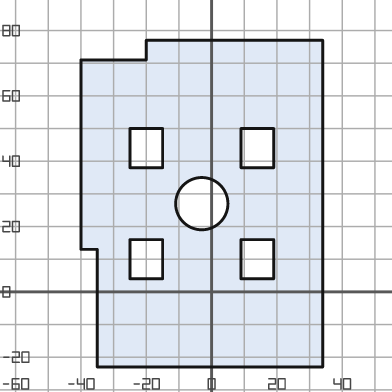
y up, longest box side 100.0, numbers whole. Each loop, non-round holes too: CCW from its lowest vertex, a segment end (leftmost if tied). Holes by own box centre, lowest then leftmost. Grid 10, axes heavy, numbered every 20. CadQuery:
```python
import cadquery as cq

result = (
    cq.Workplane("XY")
    .moveTo(-35.0, -23.0)
    .lineTo(34.0, -23.0)
    .lineTo(34.0, 77.0)
    .lineTo(-20.0, 77.0)
    .lineTo(-20.0, 71.0)
    .lineTo(-40.0, 71.0)
    .lineTo(-40.0, 13.0)
    .lineTo(-35.0, 13.0)
    .close()
    .moveTo(-25.0, 4.0)
    .lineTo(-15.0, 4.0)
    .lineTo(-15.0, 16.0)
    .lineTo(-25.0, 16.0)
    .close()
    .moveTo(9.0, 4.0)
    .lineTo(19.0, 4.0)
    .lineTo(19.0, 16.0)
    .lineTo(9.0, 16.0)
    .close()
    .moveTo(-3.0, 27.0)
    .circle(8.0)
    .moveTo(-25.0, 38.0)
    .lineTo(-15.0, 38.0)
    .lineTo(-15.0, 50.0)
    .lineTo(-25.0, 50.0)
    .close()
    .moveTo(9.0, 38.0)
    .lineTo(19.0, 38.0)
    .lineTo(19.0, 50.0)
    .lineTo(9.0, 50.0)
    .close()
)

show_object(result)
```